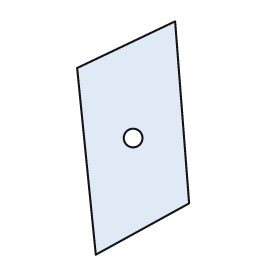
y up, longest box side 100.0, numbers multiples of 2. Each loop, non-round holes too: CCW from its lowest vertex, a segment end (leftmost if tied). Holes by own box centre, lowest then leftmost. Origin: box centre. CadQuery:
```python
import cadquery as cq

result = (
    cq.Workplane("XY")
    .moveTo(-16.0, -50.0)
    .lineTo(24.0, -28.0)
    .lineTo(18.0, 50.0)
    .lineTo(-24.0, 30.0)
    .close()
    .moveTo(0.0, 0.0)
    .circle(4.0)
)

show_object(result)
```